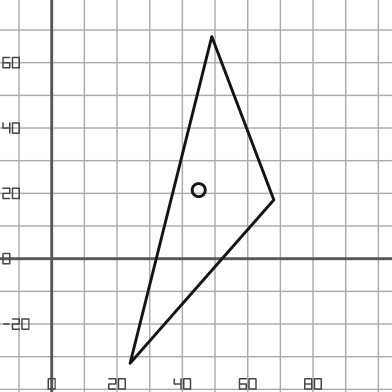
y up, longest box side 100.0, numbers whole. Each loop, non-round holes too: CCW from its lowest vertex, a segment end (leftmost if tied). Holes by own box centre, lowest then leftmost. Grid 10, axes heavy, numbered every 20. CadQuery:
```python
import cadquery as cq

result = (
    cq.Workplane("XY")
    .moveTo(24.0, -32.0)
    .lineTo(68.0, 18.0)
    .lineTo(49.0, 68.0)
    .close()
    .moveTo(45.0, 21.0)
    .circle(2.0)
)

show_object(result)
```